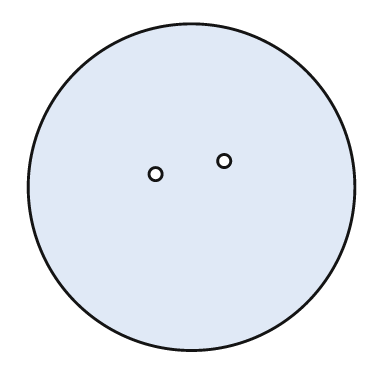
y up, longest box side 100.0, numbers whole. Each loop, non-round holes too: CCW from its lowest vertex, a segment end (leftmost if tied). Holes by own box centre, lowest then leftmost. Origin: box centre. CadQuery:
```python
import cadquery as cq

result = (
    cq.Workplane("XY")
    .moveTo(0.0, 0.0)
    .circle(50.0)
    .moveTo(-11.0, 4.0)
    .circle(2.0)
    .moveTo(10.0, 8.0)
    .circle(2.0)
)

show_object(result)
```